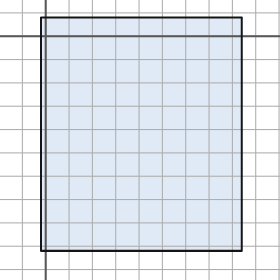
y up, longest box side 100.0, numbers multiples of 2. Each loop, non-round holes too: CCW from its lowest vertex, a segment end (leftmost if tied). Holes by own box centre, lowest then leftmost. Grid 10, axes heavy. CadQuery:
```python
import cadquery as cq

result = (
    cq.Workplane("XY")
    .moveTo(-2.0, -92.0)
    .lineTo(84.0, -92.0)
    .lineTo(84.0, 8.0)
    .lineTo(-2.0, 8.0)
    .close()
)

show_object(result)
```